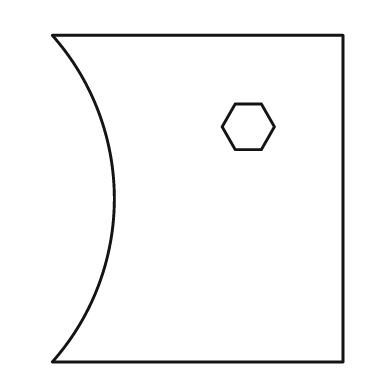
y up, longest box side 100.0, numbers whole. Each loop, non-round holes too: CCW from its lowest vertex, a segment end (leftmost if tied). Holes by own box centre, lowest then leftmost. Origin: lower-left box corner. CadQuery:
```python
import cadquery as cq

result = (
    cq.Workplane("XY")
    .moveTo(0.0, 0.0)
    .lineTo(89.0, 0.0)
    .lineTo(89.0, 100.0)
    .lineTo(0.0, 100.0)
    .threePointArc((19.0, 50.0), (0.0, 0.0))
    .close()
    .moveTo(56.0, 65.0)
    .lineTo(64.0, 65.0)
    .lineTo(68.0, 72.0)
    .lineTo(64.0, 79.0)
    .lineTo(56.0, 79.0)
    .lineTo(52.0, 72.0)
    .close()
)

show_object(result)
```